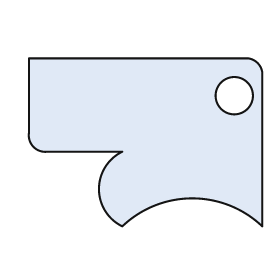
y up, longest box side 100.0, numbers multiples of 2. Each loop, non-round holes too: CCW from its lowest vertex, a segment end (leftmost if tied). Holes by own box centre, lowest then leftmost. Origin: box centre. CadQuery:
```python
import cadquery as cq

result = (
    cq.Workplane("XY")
    .moveTo(-10.0, -36.0)
    .threePointArc((20.0, -24.0), (50.0, -36.0))
    .lineTo(50.0, 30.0)
    .threePointArc((48.0, 34.0), (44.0, 36.0))
    .lineTo(-50.0, 36.0)
    .lineTo(-50.0, 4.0)
    .threePointArc((-48.0, -2.0), (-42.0, -4.0))
    .lineTo(-10.0, -4.0)
    .threePointArc((-20.0, -20.0), (-10.0, -36.0))
    .close()
    .moveTo(38.0, 20.0)
    .circle(8.0)
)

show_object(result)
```